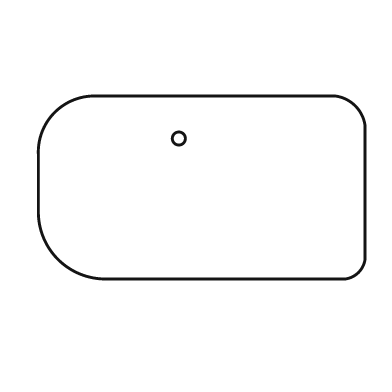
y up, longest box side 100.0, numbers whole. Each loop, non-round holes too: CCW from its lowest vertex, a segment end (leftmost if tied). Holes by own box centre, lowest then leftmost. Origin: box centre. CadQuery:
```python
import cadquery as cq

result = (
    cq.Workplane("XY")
    .moveTo(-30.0, -28.0)
    .lineTo(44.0, -28.0)
    .threePointArc((48.0, -26.0), (50.0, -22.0))
    .lineTo(50.0, 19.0)
    .threePointArc((47.0, 25.0), (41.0, 28.0))
    .lineTo(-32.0, 28.0)
    .threePointArc((-45.0, 23.0), (-50.0, 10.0))
    .lineTo(-50.0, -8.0)
    .threePointArc((-44.0, -22.0), (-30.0, -28.0))
    .close()
    .moveTo(-7.0, 15.0)
    .circle(2.0)
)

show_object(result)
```